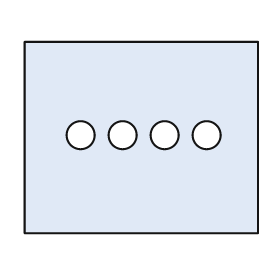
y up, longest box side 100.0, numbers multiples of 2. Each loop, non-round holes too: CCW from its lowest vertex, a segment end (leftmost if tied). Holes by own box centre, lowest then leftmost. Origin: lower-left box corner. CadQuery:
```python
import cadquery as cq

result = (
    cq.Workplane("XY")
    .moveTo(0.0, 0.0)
    .lineTo(100.0, 0.0)
    .lineTo(100.0, 82.0)
    .lineTo(0.0, 82.0)
    .close()
    .moveTo(24.0, 42.0)
    .circle(6.0)
    .moveTo(42.0, 42.0)
    .circle(6.0)
    .moveTo(60.0, 42.0)
    .circle(6.0)
    .moveTo(78.0, 42.0)
    .circle(6.0)
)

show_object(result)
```